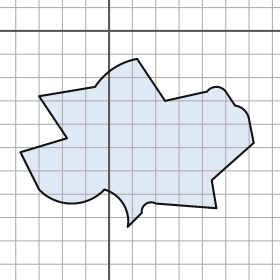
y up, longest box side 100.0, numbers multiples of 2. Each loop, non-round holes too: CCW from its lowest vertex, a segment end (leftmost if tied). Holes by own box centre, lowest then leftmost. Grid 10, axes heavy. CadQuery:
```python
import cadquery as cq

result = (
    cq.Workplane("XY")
    .moveTo(8.0, -84.0)
    .lineTo(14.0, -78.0)
    .threePointArc((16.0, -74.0), (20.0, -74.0))
    .lineTo(46.0, -76.0)
    .lineTo(44.0, -64.0)
    .lineTo(62.0, -48.0)
    .lineTo(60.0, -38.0)
    .threePointArc((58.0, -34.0), (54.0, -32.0))
    .lineTo(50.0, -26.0)
    .threePointArc((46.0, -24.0), (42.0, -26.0))
    .lineTo(24.0, -30.0)
    .lineTo(12.0, -12.0)
    .threePointArc((2.0, -16.0), (-6.0, -24.0))
    .lineTo(-30.0, -28.0)
    .lineTo(-18.0, -46.0)
    .lineTo(-38.0, -52.0)
    .lineTo(-30.0, -68.0)
    .threePointArc((-16.0, -74.0), (-2.0, -68.0))
    .threePointArc((6.0, -74.0), (8.0, -84.0))
    .close()
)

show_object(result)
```